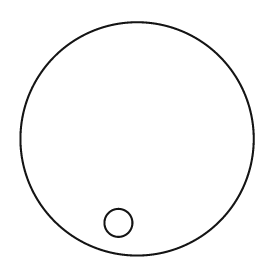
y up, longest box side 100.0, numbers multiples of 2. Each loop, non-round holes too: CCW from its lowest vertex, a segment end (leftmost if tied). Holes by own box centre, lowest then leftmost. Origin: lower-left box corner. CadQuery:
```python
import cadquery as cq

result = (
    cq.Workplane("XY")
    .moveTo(50.0, 50.0)
    .circle(50.0)
    .moveTo(42.0, 14.0)
    .circle(6.0)
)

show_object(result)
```